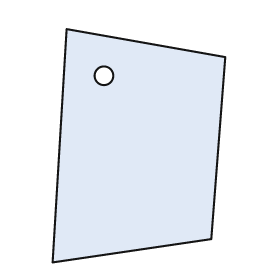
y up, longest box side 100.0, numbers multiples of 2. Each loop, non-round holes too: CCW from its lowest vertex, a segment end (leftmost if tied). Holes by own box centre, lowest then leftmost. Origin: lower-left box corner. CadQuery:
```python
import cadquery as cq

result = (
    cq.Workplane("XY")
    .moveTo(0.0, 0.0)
    .lineTo(68.0, 10.0)
    .lineTo(74.0, 88.0)
    .lineTo(6.0, 100.0)
    .close()
    .moveTo(22.0, 80.0)
    .circle(4.0)
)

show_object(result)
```